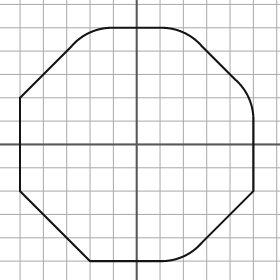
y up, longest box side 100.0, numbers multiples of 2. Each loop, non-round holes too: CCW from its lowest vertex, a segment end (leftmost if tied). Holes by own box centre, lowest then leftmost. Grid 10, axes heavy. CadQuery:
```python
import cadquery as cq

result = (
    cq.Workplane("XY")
    .moveTo(-20.0, -50.0)
    .lineTo(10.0, -50.0)
    .threePointArc((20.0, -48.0), (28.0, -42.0))
    .lineTo(50.0, -20.0)
    .lineTo(50.0, 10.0)
    .threePointArc((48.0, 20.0), (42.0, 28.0))
    .lineTo(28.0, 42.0)
    .threePointArc((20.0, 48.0), (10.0, 50.0))
    .lineTo(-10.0, 50.0)
    .threePointArc((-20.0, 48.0), (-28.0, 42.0))
    .lineTo(-50.0, 20.0)
    .lineTo(-50.0, -20.0)
    .close()
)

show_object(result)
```